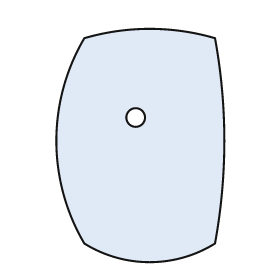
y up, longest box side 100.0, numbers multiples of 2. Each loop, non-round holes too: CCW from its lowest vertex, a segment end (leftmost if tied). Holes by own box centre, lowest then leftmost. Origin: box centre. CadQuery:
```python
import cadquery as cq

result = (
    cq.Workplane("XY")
    .moveTo(-24.0, -42.0)
    .threePointArc((4.0, -50.0), (32.0, -42.0))
    .threePointArc((36.0, 2.0), (32.0, 46.0))
    .threePointArc((4.0, 50.0), (-24.0, 46.0))
    .threePointArc((-36.0, 2.0), (-24.0, -42.0))
    .close()
    .moveTo(-2.0, 12.0)
    .circle(4.0)
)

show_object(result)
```